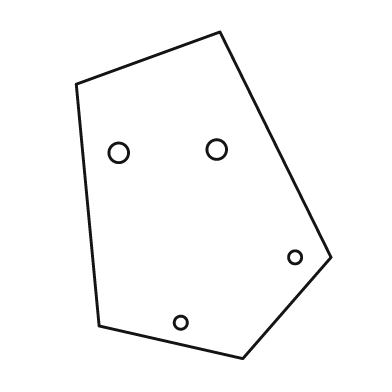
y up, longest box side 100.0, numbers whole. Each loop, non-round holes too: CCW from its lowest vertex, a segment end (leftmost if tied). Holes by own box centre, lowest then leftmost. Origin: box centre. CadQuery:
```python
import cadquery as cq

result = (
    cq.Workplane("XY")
    .moveTo(12.0, -50.0)
    .lineTo(39.0, -19.0)
    .lineTo(5.0, 50.0)
    .lineTo(-39.0, 34.0)
    .lineTo(-32.0, -40.0)
    .close()
    .moveTo(-7.0, -39.0)
    .circle(2.0)
    .moveTo(28.0, -19.0)
    .circle(2.0)
    .moveTo(-26.0, 13.0)
    .circle(3.0)
    .moveTo(4.0, 14.0)
    .circle(3.0)
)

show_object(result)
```